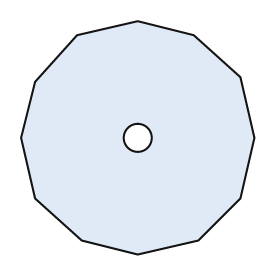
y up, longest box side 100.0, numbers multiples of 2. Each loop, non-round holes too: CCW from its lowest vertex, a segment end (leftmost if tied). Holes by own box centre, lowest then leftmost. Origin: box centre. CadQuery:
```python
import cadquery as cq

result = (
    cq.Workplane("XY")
    .moveTo(0.0, -50.0)
    .lineTo(26.0, -44.0)
    .lineTo(44.0, -26.0)
    .lineTo(50.0, 0.0)
    .lineTo(44.0, 26.0)
    .lineTo(24.0, 44.0)
    .lineTo(0.0, 50.0)
    .lineTo(-26.0, 44.0)
    .lineTo(-44.0, 24.0)
    .lineTo(-50.0, 0.0)
    .lineTo(-44.0, -26.0)
    .lineTo(-24.0, -44.0)
    .close()
    .moveTo(0.0, 0.0)
    .circle(6.0)
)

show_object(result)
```